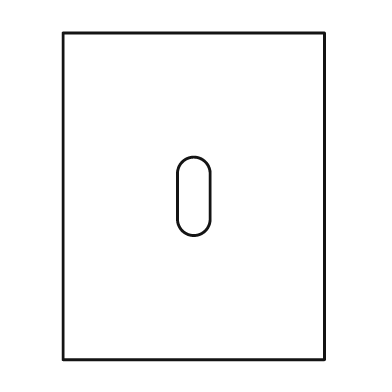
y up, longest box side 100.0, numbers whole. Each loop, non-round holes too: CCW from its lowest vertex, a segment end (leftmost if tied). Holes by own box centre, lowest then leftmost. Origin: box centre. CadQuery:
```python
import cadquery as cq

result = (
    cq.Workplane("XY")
    .moveTo(-40.0, -50.0)
    .lineTo(40.0, -50.0)
    .lineTo(40.0, 50.0)
    .lineTo(-40.0, 50.0)
    .close()
    .moveTo(-5.0, -7.0)
    .threePointArc((0.0, -12.0), (5.0, -7.0))
    .lineTo(5.0, 7.0)
    .threePointArc((0.0, 12.0), (-5.0, 7.0))
    .close()
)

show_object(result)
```